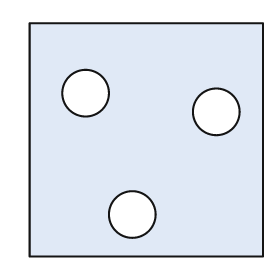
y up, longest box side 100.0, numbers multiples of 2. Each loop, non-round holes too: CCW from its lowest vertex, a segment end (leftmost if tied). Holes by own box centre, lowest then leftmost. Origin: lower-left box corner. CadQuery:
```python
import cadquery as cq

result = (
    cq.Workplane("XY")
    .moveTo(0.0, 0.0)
    .lineTo(100.0, 0.0)
    .lineTo(100.0, 100.0)
    .lineTo(0.0, 100.0)
    .close()
    .moveTo(44.0, 18.0)
    .circle(10.0)
    .moveTo(80.0, 62.0)
    .circle(10.0)
    .moveTo(24.0, 70.0)
    .circle(10.0)
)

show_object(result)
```